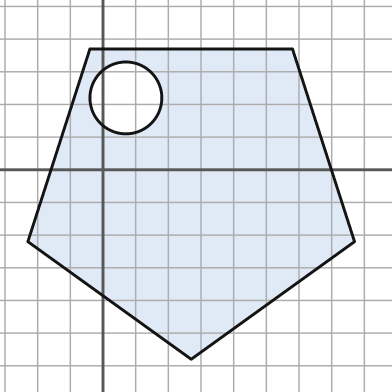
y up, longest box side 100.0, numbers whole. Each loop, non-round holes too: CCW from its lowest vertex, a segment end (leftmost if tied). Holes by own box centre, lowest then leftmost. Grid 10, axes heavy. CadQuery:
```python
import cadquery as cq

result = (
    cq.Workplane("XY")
    .moveTo(27.0, -58.0)
    .lineTo(77.0, -22.0)
    .lineTo(58.0, 37.0)
    .lineTo(-4.0, 37.0)
    .lineTo(-23.0, -22.0)
    .close()
    .moveTo(7.0, 22.0)
    .circle(11.0)
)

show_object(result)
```